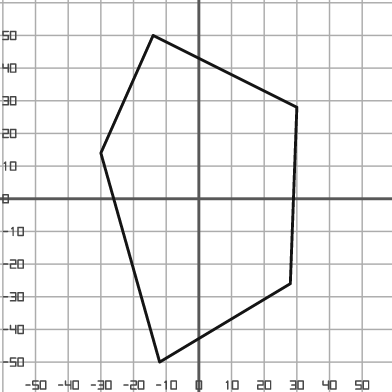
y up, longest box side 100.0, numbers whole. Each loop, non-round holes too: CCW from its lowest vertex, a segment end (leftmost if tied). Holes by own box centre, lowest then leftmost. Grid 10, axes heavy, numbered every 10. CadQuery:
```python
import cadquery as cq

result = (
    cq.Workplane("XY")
    .moveTo(-12.0, -50.0)
    .lineTo(28.0, -26.0)
    .lineTo(30.0, 28.0)
    .lineTo(-14.0, 50.0)
    .lineTo(-30.0, 14.0)
    .close()
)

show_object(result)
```